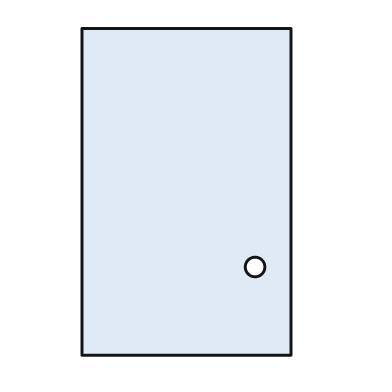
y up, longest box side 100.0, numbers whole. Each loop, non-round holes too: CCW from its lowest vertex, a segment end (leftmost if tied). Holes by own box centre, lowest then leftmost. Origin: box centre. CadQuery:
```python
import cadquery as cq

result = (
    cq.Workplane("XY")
    .moveTo(-32.0, -50.0)
    .lineTo(32.0, -50.0)
    .lineTo(32.0, 50.0)
    .lineTo(-32.0, 50.0)
    .close()
    .moveTo(21.0, -23.0)
    .circle(3.0)
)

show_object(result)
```